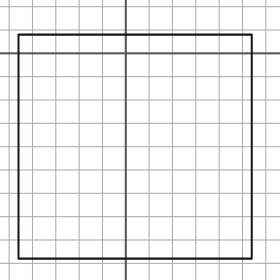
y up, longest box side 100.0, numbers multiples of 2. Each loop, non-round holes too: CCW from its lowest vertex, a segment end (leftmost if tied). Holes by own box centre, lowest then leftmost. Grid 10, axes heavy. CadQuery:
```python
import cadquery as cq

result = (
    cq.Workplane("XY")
    .moveTo(-46.0, -88.0)
    .lineTo(54.0, -88.0)
    .lineTo(54.0, 8.0)
    .lineTo(-46.0, 8.0)
    .close()
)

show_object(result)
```